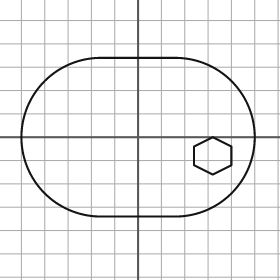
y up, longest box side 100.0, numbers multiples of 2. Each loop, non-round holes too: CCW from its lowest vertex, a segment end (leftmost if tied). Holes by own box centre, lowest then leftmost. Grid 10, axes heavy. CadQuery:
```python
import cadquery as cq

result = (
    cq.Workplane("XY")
    .moveTo(-16.0, -34.0)
    .lineTo(16.0, -34.0)
    .threePointArc((50.0, 0.0), (16.0, 34.0))
    .lineTo(-16.0, 34.0)
    .threePointArc((-50.0, 0.0), (-16.0, -34.0))
    .close()
    .moveTo(32.0, -16.0)
    .lineTo(40.0, -12.0)
    .lineTo(40.0, -4.0)
    .lineTo(32.0, 0.0)
    .lineTo(24.0, -4.0)
    .lineTo(24.0, -12.0)
    .close()
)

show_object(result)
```